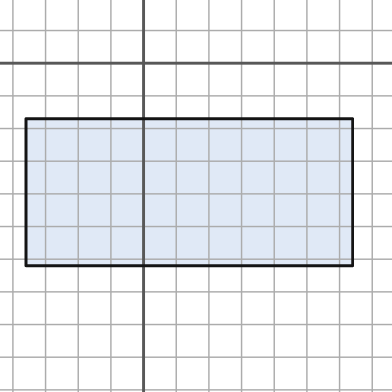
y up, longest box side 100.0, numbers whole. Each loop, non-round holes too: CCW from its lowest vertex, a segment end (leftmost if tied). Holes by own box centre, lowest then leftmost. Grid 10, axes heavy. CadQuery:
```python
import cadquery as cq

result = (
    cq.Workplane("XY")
    .moveTo(-36.0, -62.0)
    .lineTo(64.0, -62.0)
    .lineTo(64.0, -17.0)
    .lineTo(-36.0, -17.0)
    .close()
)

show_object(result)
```